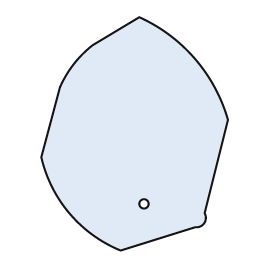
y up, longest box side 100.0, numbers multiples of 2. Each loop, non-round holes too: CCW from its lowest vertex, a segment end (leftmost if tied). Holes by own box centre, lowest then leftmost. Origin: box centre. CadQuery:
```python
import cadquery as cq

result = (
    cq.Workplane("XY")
    .moveTo(-6.0, -50.0)
    .lineTo(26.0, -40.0)
    .threePointArc((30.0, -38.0), (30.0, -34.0))
    .lineTo(40.0, 6.0)
    .threePointArc((26.0, 32.0), (2.0, 50.0))
    .lineTo(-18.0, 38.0)
    .threePointArc((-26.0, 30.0), (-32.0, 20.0))
    .lineTo(-40.0, -10.0)
    .threePointArc((-28.0, -34.0), (-6.0, -50.0))
    .close()
    .moveTo(4.0, -30.0)
    .circle(2.0)
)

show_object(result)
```